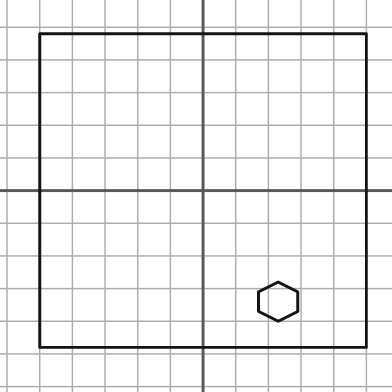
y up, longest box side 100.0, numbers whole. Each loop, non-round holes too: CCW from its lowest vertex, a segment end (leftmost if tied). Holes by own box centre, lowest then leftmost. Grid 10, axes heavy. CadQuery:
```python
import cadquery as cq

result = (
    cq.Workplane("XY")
    .moveTo(-50.0, -48.0)
    .lineTo(50.0, -48.0)
    .lineTo(50.0, 48.0)
    .lineTo(-50.0, 48.0)
    .close()
    .moveTo(23.0, -40.0)
    .lineTo(29.0, -37.0)
    .lineTo(29.0, -31.0)
    .lineTo(23.0, -28.0)
    .lineTo(17.0, -31.0)
    .lineTo(17.0, -37.0)
    .close()
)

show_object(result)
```